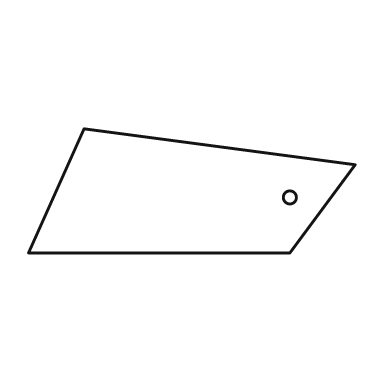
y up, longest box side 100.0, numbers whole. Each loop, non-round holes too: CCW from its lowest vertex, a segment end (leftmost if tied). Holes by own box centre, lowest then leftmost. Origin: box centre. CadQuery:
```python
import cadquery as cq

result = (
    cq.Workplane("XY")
    .moveTo(-50.0, -19.0)
    .lineTo(30.0, -19.0)
    .lineTo(50.0, 8.0)
    .lineTo(-33.0, 19.0)
    .close()
    .moveTo(30.0, -2.0)
    .circle(2.0)
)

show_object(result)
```